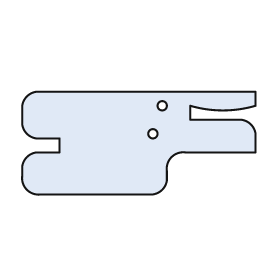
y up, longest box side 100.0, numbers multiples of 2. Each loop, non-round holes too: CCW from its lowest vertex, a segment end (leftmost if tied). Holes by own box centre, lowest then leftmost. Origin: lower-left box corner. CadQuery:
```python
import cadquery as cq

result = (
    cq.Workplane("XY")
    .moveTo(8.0, 0.0)
    .lineTo(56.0, 0.0)
    .threePointArc((60.0, 2.0), (62.0, 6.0))
    .lineTo(62.0, 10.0)
    .threePointArc((64.0, 16.0), (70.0, 18.0))
    .lineTo(100.0, 18.0)
    .lineTo(100.0, 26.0)
    .threePointArc((98.0, 30.0), (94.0, 32.0))
    .lineTo(72.0, 32.0)
    .lineTo(72.0, 38.0)
    .threePointArc((86.0, 36.0), (100.0, 38.0))
    .lineTo(100.0, 44.0)
    .lineTo(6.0, 44.0)
    .threePointArc((2.0, 42.0), (0.0, 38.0))
    .lineTo(0.0, 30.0)
    .threePointArc((2.0, 26.0), (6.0, 24.0))
    .lineTo(16.0, 24.0)
    .lineTo(16.0, 18.0)
    .lineTo(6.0, 18.0)
    .threePointArc((2.0, 16.0), (0.0, 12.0))
    .lineTo(0.0, 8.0)
    .threePointArc((2.0, 2.0), (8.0, 0.0))
    .close()
    .moveTo(56.0, 26.0)
    .circle(2.0)
    .moveTo(60.0, 38.0)
    .circle(2.0)
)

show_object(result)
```